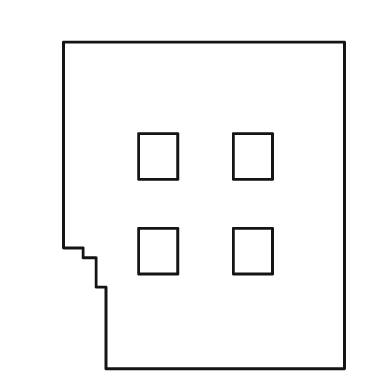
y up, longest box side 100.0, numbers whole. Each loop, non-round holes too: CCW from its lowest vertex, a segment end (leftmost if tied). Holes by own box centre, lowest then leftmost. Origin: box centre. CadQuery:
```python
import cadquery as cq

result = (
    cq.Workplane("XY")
    .moveTo(-30.0, -50.0)
    .lineTo(43.0, -50.0)
    .lineTo(43.0, 50.0)
    .lineTo(-43.0, 50.0)
    .lineTo(-43.0, -13.0)
    .lineTo(-37.0, -13.0)
    .lineTo(-37.0, -16.0)
    .lineTo(-33.0, -16.0)
    .lineTo(-33.0, -25.0)
    .lineTo(-30.0, -25.0)
    .close()
    .moveTo(-20.0, -21.0)
    .lineTo(-8.0, -21.0)
    .lineTo(-8.0, -7.0)
    .lineTo(-20.0, -7.0)
    .close()
    .moveTo(9.0, -21.0)
    .lineTo(21.0, -21.0)
    .lineTo(21.0, -7.0)
    .lineTo(9.0, -7.0)
    .close()
    .moveTo(-20.0, 8.0)
    .lineTo(-8.0, 8.0)
    .lineTo(-8.0, 22.0)
    .lineTo(-20.0, 22.0)
    .close()
    .moveTo(9.0, 8.0)
    .lineTo(21.0, 8.0)
    .lineTo(21.0, 22.0)
    .lineTo(9.0, 22.0)
    .close()
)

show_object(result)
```